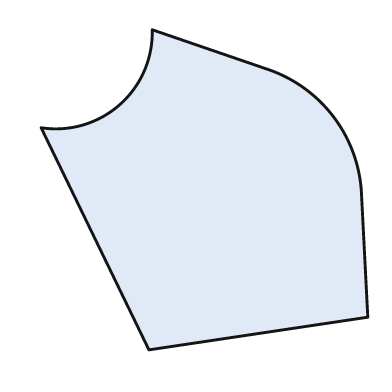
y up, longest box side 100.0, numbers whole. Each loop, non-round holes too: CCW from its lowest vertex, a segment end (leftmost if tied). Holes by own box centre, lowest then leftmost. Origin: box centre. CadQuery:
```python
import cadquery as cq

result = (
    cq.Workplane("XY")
    .moveTo(-17.0, -49.0)
    .lineTo(50.0, -39.0)
    .lineTo(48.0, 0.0)
    .threePointArc((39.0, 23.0), (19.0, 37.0))
    .lineTo(-16.0, 49.0)
    .threePointArc((-26.0, 26.0), (-50.0, 19.0))
    .close()
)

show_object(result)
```